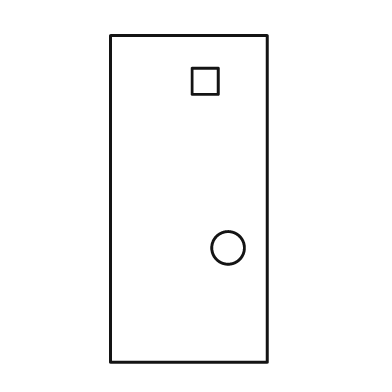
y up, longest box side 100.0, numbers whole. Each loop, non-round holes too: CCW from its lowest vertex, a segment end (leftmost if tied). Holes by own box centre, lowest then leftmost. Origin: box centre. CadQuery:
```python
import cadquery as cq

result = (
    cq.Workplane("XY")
    .moveTo(-24.0, -50.0)
    .lineTo(24.0, -50.0)
    .lineTo(24.0, 50.0)
    .lineTo(-24.0, 50.0)
    .close()
    .moveTo(12.0, -15.0)
    .circle(5.0)
    .moveTo(1.0, 32.0)
    .lineTo(9.0, 32.0)
    .lineTo(9.0, 40.0)
    .lineTo(1.0, 40.0)
    .close()
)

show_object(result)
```